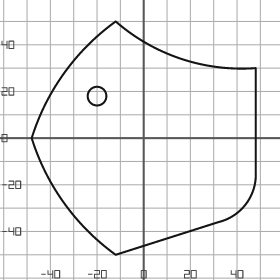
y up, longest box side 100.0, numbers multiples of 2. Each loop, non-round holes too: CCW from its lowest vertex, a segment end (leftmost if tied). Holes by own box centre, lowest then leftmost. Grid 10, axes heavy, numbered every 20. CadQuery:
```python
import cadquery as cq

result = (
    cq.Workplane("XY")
    .moveTo(-12.0, -50.0)
    .lineTo(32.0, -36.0)
    .threePointArc((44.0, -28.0), (48.0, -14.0))
    .lineTo(48.0, 30.0)
    .threePointArc((16.0, 34.0), (-12.0, 50.0))
    .threePointArc((-34.0, 28.0), (-48.0, 0.0))
    .threePointArc((-34.0, -28.0), (-12.0, -50.0))
    .close()
    .moveTo(-20.0, 18.0)
    .circle(4.0)
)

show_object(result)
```